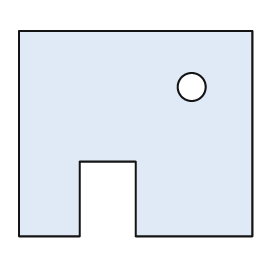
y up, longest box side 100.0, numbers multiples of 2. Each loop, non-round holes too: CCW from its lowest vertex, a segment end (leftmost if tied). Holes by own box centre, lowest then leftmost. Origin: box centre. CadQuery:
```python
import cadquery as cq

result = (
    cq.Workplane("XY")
    .moveTo(-50.0, -44.0)
    .lineTo(-24.0, -44.0)
    .lineTo(-24.0, -12.0)
    .lineTo(0.0, -12.0)
    .lineTo(0.0, -44.0)
    .lineTo(50.0, -44.0)
    .lineTo(50.0, 44.0)
    .lineTo(-50.0, 44.0)
    .close()
    .moveTo(24.0, 20.0)
    .circle(6.0)
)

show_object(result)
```